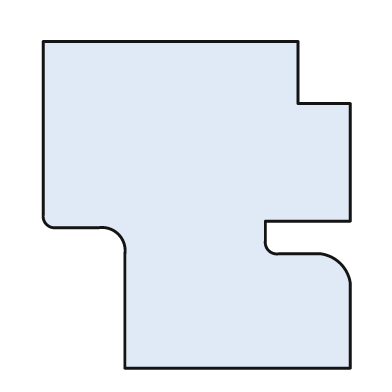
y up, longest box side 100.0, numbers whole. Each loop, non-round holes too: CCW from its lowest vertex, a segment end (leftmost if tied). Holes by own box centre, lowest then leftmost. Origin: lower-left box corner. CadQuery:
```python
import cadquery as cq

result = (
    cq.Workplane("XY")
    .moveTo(25.0, 0.0)
    .lineTo(94.0, 0.0)
    .lineTo(94.0, 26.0)
    .threePointArc((91.0, 32.0), (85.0, 35.0))
    .lineTo(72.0, 35.0)
    .threePointArc((69.0, 36.0), (68.0, 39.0))
    .lineTo(68.0, 45.0)
    .lineTo(94.0, 45.0)
    .lineTo(94.0, 81.0)
    .lineTo(78.0, 81.0)
    .lineTo(78.0, 100.0)
    .lineTo(0.0, 100.0)
    .lineTo(0.0, 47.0)
    .threePointArc((1.0, 44.0), (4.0, 43.0))
    .lineTo(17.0, 43.0)
    .threePointArc((23.0, 41.0), (25.0, 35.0))
    .close()
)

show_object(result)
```